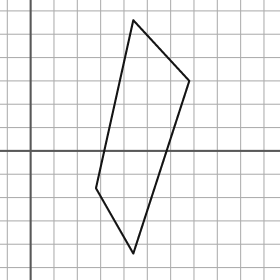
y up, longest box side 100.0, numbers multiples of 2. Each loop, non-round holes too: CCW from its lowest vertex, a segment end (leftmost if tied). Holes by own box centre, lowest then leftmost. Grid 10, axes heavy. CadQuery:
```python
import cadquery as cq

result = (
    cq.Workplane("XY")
    .moveTo(44.0, -44.0)
    .lineTo(68.0, 30.0)
    .lineTo(44.0, 56.0)
    .lineTo(28.0, -16.0)
    .close()
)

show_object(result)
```